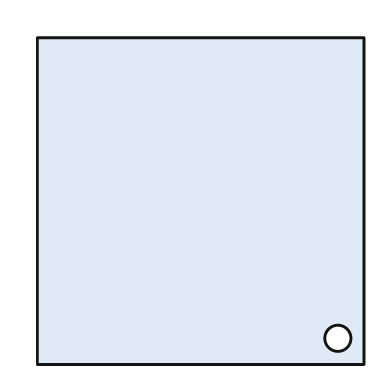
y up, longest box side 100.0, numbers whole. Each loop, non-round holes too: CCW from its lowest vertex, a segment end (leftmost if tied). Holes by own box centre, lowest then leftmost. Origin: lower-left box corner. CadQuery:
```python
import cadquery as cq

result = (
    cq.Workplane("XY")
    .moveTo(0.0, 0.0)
    .lineTo(100.0, 0.0)
    .lineTo(100.0, 100.0)
    .lineTo(0.0, 100.0)
    .close()
    .moveTo(92.0, 8.0)
    .circle(4.0)
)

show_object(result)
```